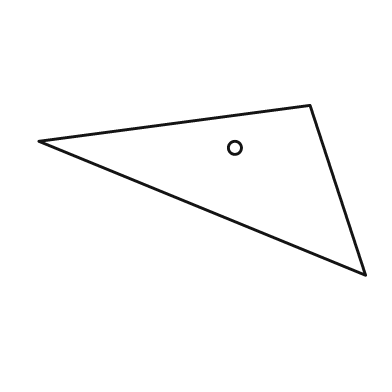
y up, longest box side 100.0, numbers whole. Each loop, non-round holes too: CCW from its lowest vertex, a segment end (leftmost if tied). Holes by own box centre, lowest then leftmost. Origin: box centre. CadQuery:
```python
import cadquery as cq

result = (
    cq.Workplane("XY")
    .moveTo(50.0, -26.0)
    .lineTo(33.0, 26.0)
    .lineTo(-50.0, 15.0)
    .close()
    .moveTo(10.0, 13.0)
    .circle(2.0)
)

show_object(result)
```